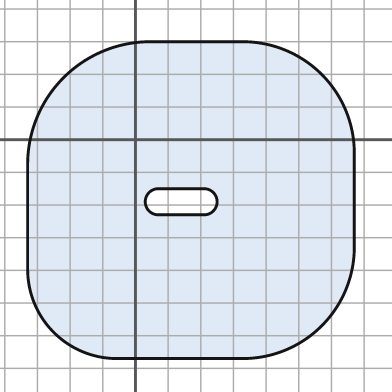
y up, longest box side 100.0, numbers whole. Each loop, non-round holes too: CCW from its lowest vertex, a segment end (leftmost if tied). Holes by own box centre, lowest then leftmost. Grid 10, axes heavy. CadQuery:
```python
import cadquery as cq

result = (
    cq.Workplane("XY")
    .moveTo(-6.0, -67.0)
    .lineTo(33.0, -67.0)
    .threePointArc((57.0, -57.0), (67.0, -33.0))
    .lineTo(67.0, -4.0)
    .threePointArc((57.0, 20.0), (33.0, 30.0))
    .lineTo(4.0, 30.0)
    .threePointArc((-22.0, 19.0), (-33.0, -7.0))
    .lineTo(-33.0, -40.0)
    .threePointArc((-25.0, -59.0), (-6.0, -67.0))
    .close()
    .moveTo(7.0, -23.0)
    .lineTo(21.0, -23.0)
    .threePointArc((25.0, -19.0), (21.0, -15.0))
    .lineTo(7.0, -15.0)
    .threePointArc((3.0, -19.0), (7.0, -23.0))
    .close()
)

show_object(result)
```